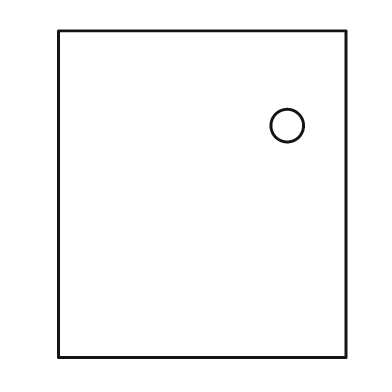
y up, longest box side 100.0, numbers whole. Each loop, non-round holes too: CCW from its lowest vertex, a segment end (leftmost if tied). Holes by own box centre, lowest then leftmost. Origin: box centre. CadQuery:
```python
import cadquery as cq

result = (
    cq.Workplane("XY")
    .moveTo(-44.0, -50.0)
    .lineTo(44.0, -50.0)
    .lineTo(44.0, 50.0)
    .lineTo(-44.0, 50.0)
    .close()
    .moveTo(26.0, 21.0)
    .circle(5.0)
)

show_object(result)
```